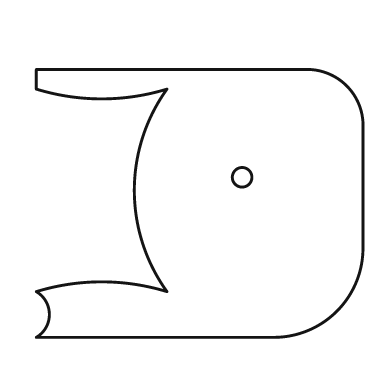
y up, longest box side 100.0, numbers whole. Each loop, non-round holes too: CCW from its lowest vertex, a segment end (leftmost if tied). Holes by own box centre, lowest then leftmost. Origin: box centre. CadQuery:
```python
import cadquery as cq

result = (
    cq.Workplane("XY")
    .moveTo(-50.0, -41.0)
    .lineTo(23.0, -41.0)
    .threePointArc((42.0, -33.0), (50.0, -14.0))
    .lineTo(50.0, 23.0)
    .threePointArc((45.0, 36.0), (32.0, 41.0))
    .lineTo(-50.0, 41.0)
    .lineTo(-50.0, 35.0)
    .threePointArc((-30.0, 32.0), (-10.0, 35.0))
    .threePointArc((-20.0, 4.0), (-10.0, -27.0))
    .threePointArc((-30.0, -24.0), (-50.0, -27.0))
    .threePointArc((-46.0, -34.0), (-50.0, -41.0))
    .close()
    .moveTo(13.0, 8.0)
    .circle(3.0)
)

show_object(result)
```